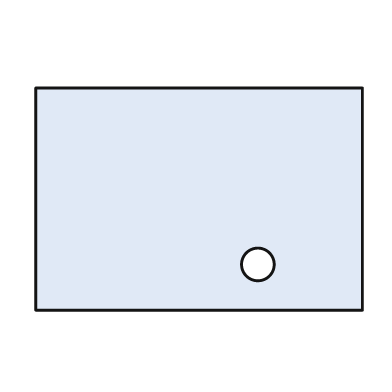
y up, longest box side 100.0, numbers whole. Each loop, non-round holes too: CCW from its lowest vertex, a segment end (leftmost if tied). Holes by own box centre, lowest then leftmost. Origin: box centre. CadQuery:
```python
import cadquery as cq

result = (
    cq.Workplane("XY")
    .moveTo(-50.0, -34.0)
    .lineTo(50.0, -34.0)
    .lineTo(50.0, 34.0)
    .lineTo(-50.0, 34.0)
    .close()
    .moveTo(18.0, -20.0)
    .circle(5.0)
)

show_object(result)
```